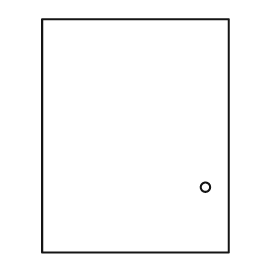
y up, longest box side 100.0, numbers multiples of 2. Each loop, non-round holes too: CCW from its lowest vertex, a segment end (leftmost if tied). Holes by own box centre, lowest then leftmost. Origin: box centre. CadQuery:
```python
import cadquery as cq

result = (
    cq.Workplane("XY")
    .moveTo(-40.0, -50.0)
    .lineTo(40.0, -50.0)
    .lineTo(40.0, 50.0)
    .lineTo(-40.0, 50.0)
    .close()
    .moveTo(30.0, -22.0)
    .circle(2.0)
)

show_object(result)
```